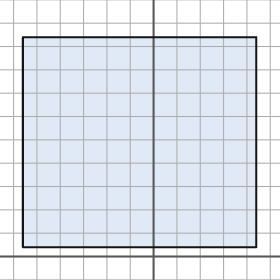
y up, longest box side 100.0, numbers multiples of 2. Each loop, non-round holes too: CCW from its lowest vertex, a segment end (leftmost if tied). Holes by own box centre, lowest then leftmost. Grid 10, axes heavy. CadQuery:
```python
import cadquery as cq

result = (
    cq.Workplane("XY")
    .moveTo(-56.0, 4.0)
    .lineTo(44.0, 4.0)
    .lineTo(44.0, 94.0)
    .lineTo(-56.0, 94.0)
    .close()
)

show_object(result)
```